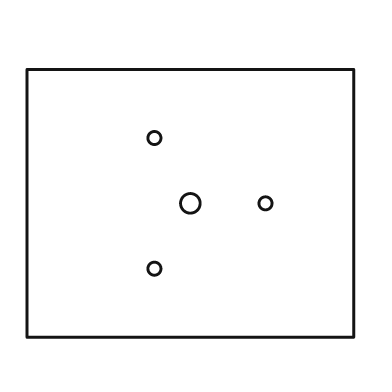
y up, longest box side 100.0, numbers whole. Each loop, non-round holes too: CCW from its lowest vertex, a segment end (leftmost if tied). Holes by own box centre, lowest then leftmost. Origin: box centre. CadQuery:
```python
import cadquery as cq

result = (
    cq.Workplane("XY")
    .moveTo(-50.0, -41.0)
    .lineTo(50.0, -41.0)
    .lineTo(50.0, 41.0)
    .lineTo(-50.0, 41.0)
    .close()
    .moveTo(-11.0, -20.0)
    .circle(2.0)
    .moveTo(0.0, 0.0)
    .circle(3.0)
    .moveTo(23.0, 0.0)
    .circle(2.0)
    .moveTo(-11.0, 20.0)
    .circle(2.0)
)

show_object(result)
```